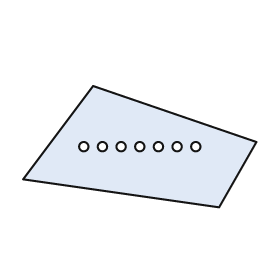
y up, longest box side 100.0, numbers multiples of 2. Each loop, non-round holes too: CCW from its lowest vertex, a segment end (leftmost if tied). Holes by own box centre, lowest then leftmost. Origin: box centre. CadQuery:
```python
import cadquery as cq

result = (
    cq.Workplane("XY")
    .moveTo(34.0, -26.0)
    .lineTo(50.0, 2.0)
    .lineTo(-20.0, 26.0)
    .lineTo(-50.0, -14.0)
    .close()
    .moveTo(-24.0, 0.0)
    .circle(2.0)
    .moveTo(-16.0, 0.0)
    .circle(2.0)
    .moveTo(-8.0, 0.0)
    .circle(2.0)
    .moveTo(0.0, 0.0)
    .circle(2.0)
    .moveTo(8.0, 0.0)
    .circle(2.0)
    .moveTo(16.0, 0.0)
    .circle(2.0)
    .moveTo(24.0, 0.0)
    .circle(2.0)
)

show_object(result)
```